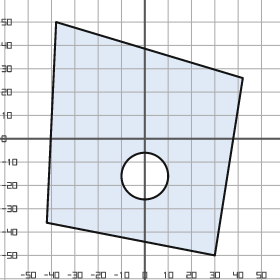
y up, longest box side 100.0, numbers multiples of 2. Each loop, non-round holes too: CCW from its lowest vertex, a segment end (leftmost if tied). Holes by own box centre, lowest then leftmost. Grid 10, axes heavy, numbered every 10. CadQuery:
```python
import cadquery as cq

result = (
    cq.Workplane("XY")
    .moveTo(30.0, -50.0)
    .lineTo(42.0, 26.0)
    .lineTo(-38.0, 50.0)
    .lineTo(-42.0, -36.0)
    .close()
    .moveTo(0.0, -16.0)
    .circle(10.0)
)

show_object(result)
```